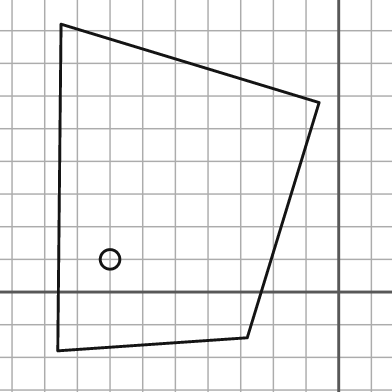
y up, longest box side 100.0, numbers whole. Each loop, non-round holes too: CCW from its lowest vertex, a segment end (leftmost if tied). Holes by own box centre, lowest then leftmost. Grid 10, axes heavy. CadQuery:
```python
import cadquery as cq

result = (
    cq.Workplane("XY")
    .moveTo(-86.0, -18.0)
    .lineTo(-28.0, -14.0)
    .lineTo(-6.0, 58.0)
    .lineTo(-85.0, 82.0)
    .close()
    .moveTo(-70.0, 10.0)
    .circle(3.0)
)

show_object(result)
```